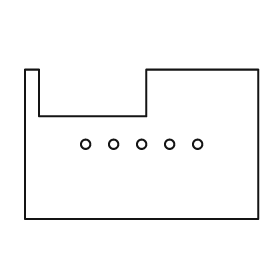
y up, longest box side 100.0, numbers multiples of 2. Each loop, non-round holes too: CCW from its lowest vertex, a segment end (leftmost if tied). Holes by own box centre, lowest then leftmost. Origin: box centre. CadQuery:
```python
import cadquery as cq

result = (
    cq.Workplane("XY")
    .moveTo(-50.0, -32.0)
    .lineTo(50.0, -32.0)
    .lineTo(50.0, 32.0)
    .lineTo(2.0, 32.0)
    .lineTo(2.0, 12.0)
    .lineTo(-44.0, 12.0)
    .lineTo(-44.0, 32.0)
    .lineTo(-50.0, 32.0)
    .close()
    .moveTo(-24.0, 0.0)
    .circle(2.0)
    .moveTo(-12.0, 0.0)
    .circle(2.0)
    .moveTo(0.0, 0.0)
    .circle(2.0)
    .moveTo(12.0, 0.0)
    .circle(2.0)
    .moveTo(24.0, 0.0)
    .circle(2.0)
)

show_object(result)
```